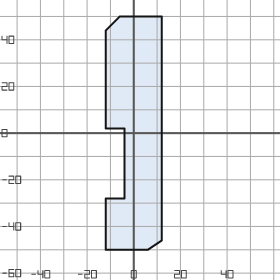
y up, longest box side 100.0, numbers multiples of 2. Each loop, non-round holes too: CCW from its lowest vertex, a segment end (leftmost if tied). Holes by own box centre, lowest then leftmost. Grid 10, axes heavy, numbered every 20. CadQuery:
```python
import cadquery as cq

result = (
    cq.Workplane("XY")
    .moveTo(-12.0, -50.0)
    .lineTo(6.0, -50.0)
    .lineTo(12.0, -46.0)
    .lineTo(12.0, 50.0)
    .lineTo(-6.0, 50.0)
    .lineTo(-12.0, 44.0)
    .lineTo(-12.0, 2.0)
    .lineTo(-4.0, 2.0)
    .lineTo(-4.0, -28.0)
    .lineTo(-12.0, -28.0)
    .close()
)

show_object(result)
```